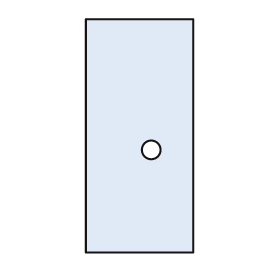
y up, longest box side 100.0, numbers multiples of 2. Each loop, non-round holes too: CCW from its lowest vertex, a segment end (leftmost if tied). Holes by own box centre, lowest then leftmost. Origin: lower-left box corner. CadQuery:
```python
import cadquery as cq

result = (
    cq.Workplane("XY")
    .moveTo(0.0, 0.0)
    .lineTo(46.0, 0.0)
    .lineTo(46.0, 100.0)
    .lineTo(0.0, 100.0)
    .close()
    .moveTo(28.0, 44.0)
    .circle(4.0)
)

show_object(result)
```